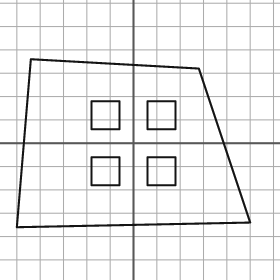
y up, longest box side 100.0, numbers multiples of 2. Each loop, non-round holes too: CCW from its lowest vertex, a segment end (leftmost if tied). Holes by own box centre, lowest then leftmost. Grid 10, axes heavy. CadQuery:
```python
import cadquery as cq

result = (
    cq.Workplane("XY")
    .moveTo(-50.0, -36.0)
    .lineTo(50.0, -34.0)
    .lineTo(28.0, 32.0)
    .lineTo(-44.0, 36.0)
    .close()
    .moveTo(-18.0, -18.0)
    .lineTo(-6.0, -18.0)
    .lineTo(-6.0, -6.0)
    .lineTo(-18.0, -6.0)
    .close()
    .moveTo(6.0, -18.0)
    .lineTo(18.0, -18.0)
    .lineTo(18.0, -6.0)
    .lineTo(6.0, -6.0)
    .close()
    .moveTo(-18.0, 6.0)
    .lineTo(-6.0, 6.0)
    .lineTo(-6.0, 18.0)
    .lineTo(-18.0, 18.0)
    .close()
    .moveTo(6.0, 6.0)
    .lineTo(18.0, 6.0)
    .lineTo(18.0, 18.0)
    .lineTo(6.0, 18.0)
    .close()
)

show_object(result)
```